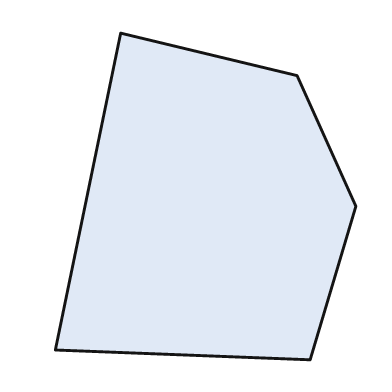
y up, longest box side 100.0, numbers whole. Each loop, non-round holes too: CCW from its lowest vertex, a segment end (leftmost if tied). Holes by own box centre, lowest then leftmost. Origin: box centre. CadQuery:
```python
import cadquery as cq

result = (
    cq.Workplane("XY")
    .moveTo(32.0, -50.0)
    .lineTo(46.0, -3.0)
    .lineTo(28.0, 37.0)
    .lineTo(-26.0, 50.0)
    .lineTo(-46.0, -47.0)
    .close()
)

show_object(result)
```